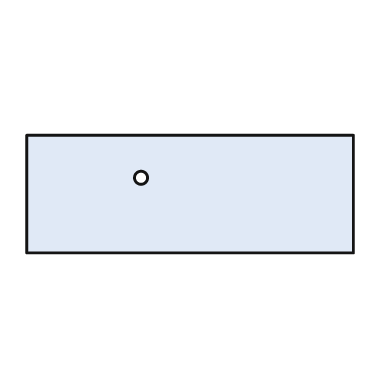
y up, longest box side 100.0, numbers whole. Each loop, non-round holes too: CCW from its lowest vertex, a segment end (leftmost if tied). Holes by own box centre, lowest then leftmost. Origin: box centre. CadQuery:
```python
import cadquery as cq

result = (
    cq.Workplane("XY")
    .moveTo(-50.0, -18.0)
    .lineTo(50.0, -18.0)
    .lineTo(50.0, 18.0)
    .lineTo(-50.0, 18.0)
    .close()
    .moveTo(-15.0, 5.0)
    .circle(2.0)
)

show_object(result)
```